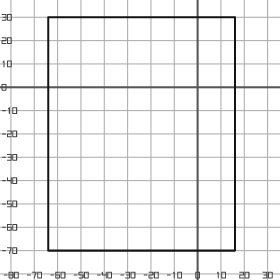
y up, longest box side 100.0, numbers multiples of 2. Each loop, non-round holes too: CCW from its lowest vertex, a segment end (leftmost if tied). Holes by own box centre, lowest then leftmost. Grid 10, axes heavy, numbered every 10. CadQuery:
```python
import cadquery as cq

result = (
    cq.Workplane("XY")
    .moveTo(-64.0, -70.0)
    .lineTo(16.0, -70.0)
    .lineTo(16.0, 30.0)
    .lineTo(-64.0, 30.0)
    .close()
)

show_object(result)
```